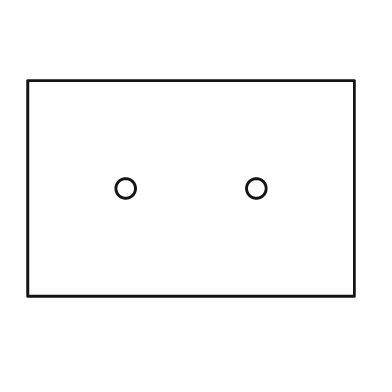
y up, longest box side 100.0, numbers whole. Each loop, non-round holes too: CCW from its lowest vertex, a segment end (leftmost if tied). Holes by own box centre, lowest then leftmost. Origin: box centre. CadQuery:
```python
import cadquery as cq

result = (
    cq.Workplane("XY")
    .moveTo(-50.0, -33.0)
    .lineTo(50.0, -33.0)
    .lineTo(50.0, 33.0)
    .lineTo(-50.0, 33.0)
    .close()
    .moveTo(-20.0, 0.0)
    .circle(3.0)
    .moveTo(20.0, 0.0)
    .circle(3.0)
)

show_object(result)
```